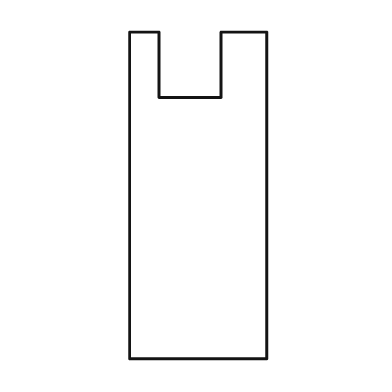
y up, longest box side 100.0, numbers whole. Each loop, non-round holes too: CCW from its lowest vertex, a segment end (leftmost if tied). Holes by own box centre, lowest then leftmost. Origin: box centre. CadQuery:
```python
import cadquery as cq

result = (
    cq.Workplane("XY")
    .moveTo(-21.0, -50.0)
    .lineTo(21.0, -50.0)
    .lineTo(21.0, 50.0)
    .lineTo(7.0, 50.0)
    .lineTo(7.0, 30.0)
    .lineTo(-12.0, 30.0)
    .lineTo(-12.0, 50.0)
    .lineTo(-21.0, 50.0)
    .close()
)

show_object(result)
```